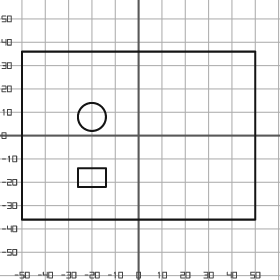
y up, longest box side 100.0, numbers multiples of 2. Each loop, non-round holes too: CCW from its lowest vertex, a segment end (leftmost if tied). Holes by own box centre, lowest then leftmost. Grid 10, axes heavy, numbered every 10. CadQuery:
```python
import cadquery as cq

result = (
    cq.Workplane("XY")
    .moveTo(-50.0, -36.0)
    .lineTo(50.0, -36.0)
    .lineTo(50.0, 36.0)
    .lineTo(-50.0, 36.0)
    .close()
    .moveTo(-26.0, -22.0)
    .lineTo(-14.0, -22.0)
    .lineTo(-14.0, -14.0)
    .lineTo(-26.0, -14.0)
    .close()
    .moveTo(-20.0, 8.0)
    .circle(6.0)
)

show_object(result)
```